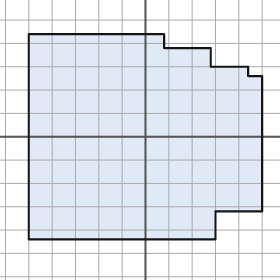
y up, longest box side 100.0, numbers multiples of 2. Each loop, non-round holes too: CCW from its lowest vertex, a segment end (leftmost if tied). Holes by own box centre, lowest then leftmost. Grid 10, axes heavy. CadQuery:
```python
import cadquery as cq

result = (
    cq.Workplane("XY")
    .moveTo(-50.0, -44.0)
    .lineTo(30.0, -44.0)
    .lineTo(30.0, -32.0)
    .lineTo(50.0, -32.0)
    .lineTo(50.0, 26.0)
    .lineTo(44.0, 26.0)
    .lineTo(44.0, 30.0)
    .lineTo(28.0, 30.0)
    .lineTo(28.0, 38.0)
    .lineTo(8.0, 38.0)
    .lineTo(8.0, 44.0)
    .lineTo(-50.0, 44.0)
    .close()
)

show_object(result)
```